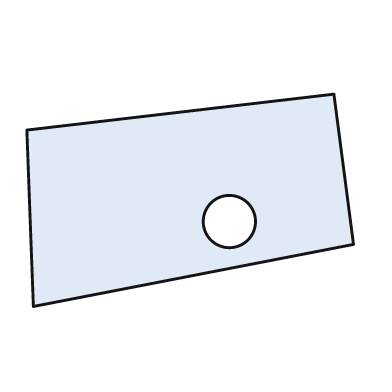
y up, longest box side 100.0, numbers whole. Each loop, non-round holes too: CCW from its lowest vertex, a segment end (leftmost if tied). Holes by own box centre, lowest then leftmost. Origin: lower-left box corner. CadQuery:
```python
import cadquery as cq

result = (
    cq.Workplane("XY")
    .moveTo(2.0, 0.0)
    .lineTo(100.0, 19.0)
    .lineTo(94.0, 65.0)
    .lineTo(0.0, 54.0)
    .close()
    .moveTo(62.0, 26.0)
    .circle(8.0)
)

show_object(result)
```